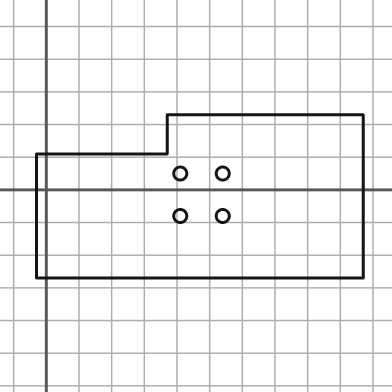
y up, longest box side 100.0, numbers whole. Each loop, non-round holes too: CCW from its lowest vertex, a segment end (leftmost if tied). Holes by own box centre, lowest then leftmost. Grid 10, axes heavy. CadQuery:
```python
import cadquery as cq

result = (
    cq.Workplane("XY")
    .moveTo(-3.0, -27.0)
    .lineTo(97.0, -27.0)
    .lineTo(97.0, 23.0)
    .lineTo(37.0, 23.0)
    .lineTo(37.0, 11.0)
    .lineTo(-3.0, 11.0)
    .close()
    .moveTo(41.0, -8.0)
    .circle(2.0)
    .moveTo(54.0, -8.0)
    .circle(2.0)
    .moveTo(41.0, 5.0)
    .circle(2.0)
    .moveTo(54.0, 5.0)
    .circle(2.0)
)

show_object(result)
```